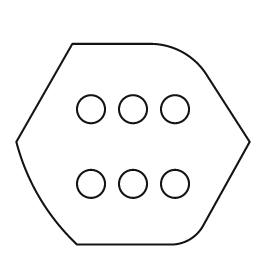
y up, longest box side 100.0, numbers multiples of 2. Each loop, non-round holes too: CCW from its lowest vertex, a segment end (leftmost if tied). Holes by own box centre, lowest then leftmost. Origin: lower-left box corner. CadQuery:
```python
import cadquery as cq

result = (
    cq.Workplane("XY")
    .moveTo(26.0, 0.0)
    .lineTo(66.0, 0.0)
    .threePointArc((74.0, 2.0), (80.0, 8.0))
    .lineTo(100.0, 44.0)
    .lineTo(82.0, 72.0)
    .threePointArc((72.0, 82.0), (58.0, 86.0))
    .lineTo(24.0, 86.0)
    .lineTo(0.0, 44.0)
    .threePointArc((10.0, 20.0), (26.0, 0.0))
    .close()
    .moveTo(32.0, 26.0)
    .circle(6.0)
    .moveTo(50.0, 26.0)
    .circle(6.0)
    .moveTo(68.0, 26.0)
    .circle(6.0)
    .moveTo(32.0, 58.0)
    .circle(6.0)
    .moveTo(50.0, 58.0)
    .circle(6.0)
    .moveTo(68.0, 58.0)
    .circle(6.0)
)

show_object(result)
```